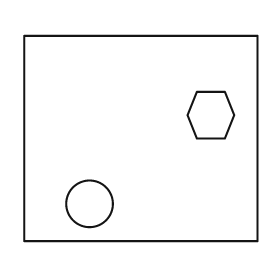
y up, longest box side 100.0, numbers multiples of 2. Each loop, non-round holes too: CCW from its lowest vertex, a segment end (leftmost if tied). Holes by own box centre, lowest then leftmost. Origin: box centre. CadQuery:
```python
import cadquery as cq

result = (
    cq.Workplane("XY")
    .moveTo(-50.0, -44.0)
    .lineTo(50.0, -44.0)
    .lineTo(50.0, 44.0)
    .lineTo(-50.0, 44.0)
    .close()
    .moveTo(-22.0, -28.0)
    .circle(10.0)
    .moveTo(24.0, 0.0)
    .lineTo(36.0, 0.0)
    .lineTo(40.0, 10.0)
    .lineTo(36.0, 20.0)
    .lineTo(24.0, 20.0)
    .lineTo(20.0, 10.0)
    .close()
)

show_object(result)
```